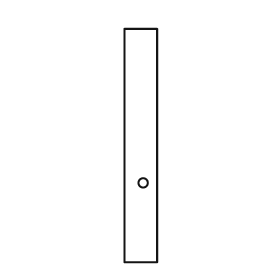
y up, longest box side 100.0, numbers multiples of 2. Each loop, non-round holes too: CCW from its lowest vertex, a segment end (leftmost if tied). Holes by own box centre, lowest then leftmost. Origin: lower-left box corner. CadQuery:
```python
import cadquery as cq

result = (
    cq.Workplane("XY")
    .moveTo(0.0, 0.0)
    .lineTo(14.0, 0.0)
    .lineTo(14.0, 100.0)
    .lineTo(0.0, 100.0)
    .close()
    .moveTo(8.0, 34.0)
    .circle(2.0)
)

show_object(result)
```